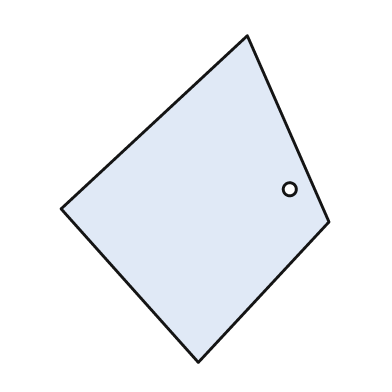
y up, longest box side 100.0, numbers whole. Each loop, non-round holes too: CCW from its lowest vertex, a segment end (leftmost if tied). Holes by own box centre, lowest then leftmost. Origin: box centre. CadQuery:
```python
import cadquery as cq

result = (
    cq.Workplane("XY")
    .moveTo(1.0, -50.0)
    .lineTo(41.0, -7.0)
    .lineTo(16.0, 50.0)
    .lineTo(-41.0, -3.0)
    .close()
    .moveTo(29.0, 3.0)
    .circle(2.0)
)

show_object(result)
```